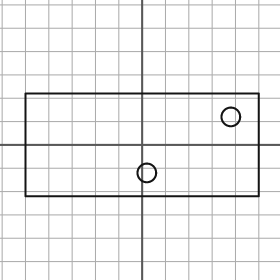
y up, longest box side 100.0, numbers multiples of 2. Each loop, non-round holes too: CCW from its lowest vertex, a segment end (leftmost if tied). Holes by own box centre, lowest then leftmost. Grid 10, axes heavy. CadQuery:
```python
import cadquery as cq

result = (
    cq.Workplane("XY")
    .moveTo(-50.0, -22.0)
    .lineTo(50.0, -22.0)
    .lineTo(50.0, 22.0)
    .lineTo(-50.0, 22.0)
    .close()
    .moveTo(2.0, -12.0)
    .circle(4.0)
    .moveTo(38.0, 12.0)
    .circle(4.0)
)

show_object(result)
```